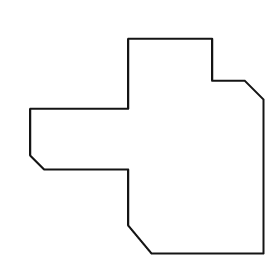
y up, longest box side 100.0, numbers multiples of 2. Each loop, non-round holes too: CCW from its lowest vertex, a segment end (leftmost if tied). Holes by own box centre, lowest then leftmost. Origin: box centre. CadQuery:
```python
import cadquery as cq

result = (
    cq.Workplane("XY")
    .moveTo(2.0, -46.0)
    .lineTo(50.0, -46.0)
    .lineTo(50.0, 20.0)
    .lineTo(42.0, 28.0)
    .lineTo(28.0, 28.0)
    .lineTo(28.0, 46.0)
    .lineTo(-8.0, 46.0)
    .lineTo(-8.0, 16.0)
    .lineTo(-50.0, 16.0)
    .lineTo(-50.0, -4.0)
    .lineTo(-44.0, -10.0)
    .lineTo(-8.0, -10.0)
    .lineTo(-8.0, -34.0)
    .close()
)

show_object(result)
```